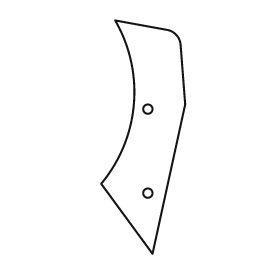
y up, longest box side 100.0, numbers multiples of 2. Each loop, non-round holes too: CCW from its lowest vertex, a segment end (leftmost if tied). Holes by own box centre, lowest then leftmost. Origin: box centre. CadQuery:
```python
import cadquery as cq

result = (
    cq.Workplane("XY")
    .moveTo(4.0, -50.0)
    .lineTo(18.0, 14.0)
    .lineTo(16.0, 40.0)
    .threePointArc((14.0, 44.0), (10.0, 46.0))
    .lineTo(-12.0, 50.0)
    .threePointArc((-4.0, 14.0), (-18.0, -20.0))
    .close()
    .moveTo(2.0, -24.0)
    .circle(2.0)
    .moveTo(2.0, 12.0)
    .circle(2.0)
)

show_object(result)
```